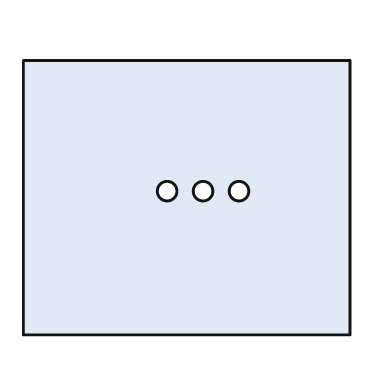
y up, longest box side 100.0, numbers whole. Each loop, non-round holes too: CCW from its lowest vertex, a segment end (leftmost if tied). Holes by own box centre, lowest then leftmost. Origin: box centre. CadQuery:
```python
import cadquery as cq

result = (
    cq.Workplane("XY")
    .moveTo(-50.0, -42.0)
    .lineTo(50.0, -42.0)
    .lineTo(50.0, 42.0)
    .lineTo(-50.0, 42.0)
    .close()
    .moveTo(-6.0, 2.0)
    .circle(3.0)
    .moveTo(5.0, 2.0)
    .circle(3.0)
    .moveTo(16.0, 2.0)
    .circle(3.0)
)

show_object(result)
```